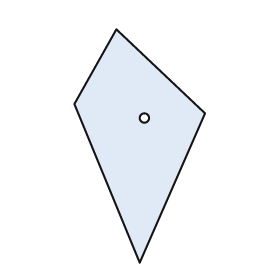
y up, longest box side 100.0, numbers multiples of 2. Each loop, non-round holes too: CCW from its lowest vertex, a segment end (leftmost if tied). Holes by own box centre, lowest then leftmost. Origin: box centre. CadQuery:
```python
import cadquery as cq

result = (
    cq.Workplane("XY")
    .moveTo(0.0, -50.0)
    .lineTo(28.0, 14.0)
    .lineTo(-10.0, 50.0)
    .lineTo(-28.0, 18.0)
    .close()
    .moveTo(2.0, 12.0)
    .circle(2.0)
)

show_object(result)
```